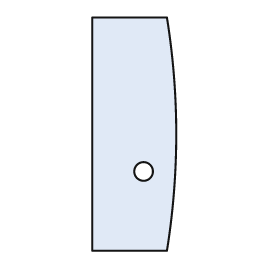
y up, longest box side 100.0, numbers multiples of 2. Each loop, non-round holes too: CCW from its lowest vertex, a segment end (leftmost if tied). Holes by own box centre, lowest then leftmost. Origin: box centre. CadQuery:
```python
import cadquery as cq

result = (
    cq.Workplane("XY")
    .moveTo(-18.0, -50.0)
    .lineTo(14.0, -50.0)
    .threePointArc((18.0, 0.0), (14.0, 50.0))
    .lineTo(-18.0, 50.0)
    .close()
    .moveTo(4.0, -16.0)
    .circle(4.0)
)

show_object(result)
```